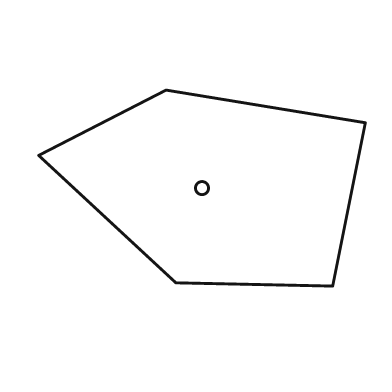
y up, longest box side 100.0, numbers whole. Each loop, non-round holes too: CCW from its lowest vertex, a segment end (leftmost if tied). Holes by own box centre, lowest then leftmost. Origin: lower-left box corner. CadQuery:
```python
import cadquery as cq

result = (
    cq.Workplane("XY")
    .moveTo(90.0, 0.0)
    .lineTo(100.0, 50.0)
    .lineTo(39.0, 60.0)
    .lineTo(0.0, 40.0)
    .lineTo(42.0, 1.0)
    .close()
    .moveTo(50.0, 30.0)
    .circle(2.0)
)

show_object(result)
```